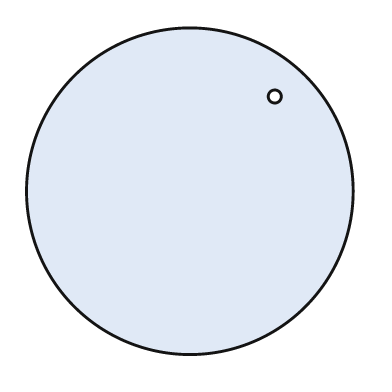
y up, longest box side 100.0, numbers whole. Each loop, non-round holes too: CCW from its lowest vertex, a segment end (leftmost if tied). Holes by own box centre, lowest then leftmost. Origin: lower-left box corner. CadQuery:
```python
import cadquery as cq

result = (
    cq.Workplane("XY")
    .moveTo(50.0, 50.0)
    .circle(50.0)
    .moveTo(76.0, 79.0)
    .circle(2.0)
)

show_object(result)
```